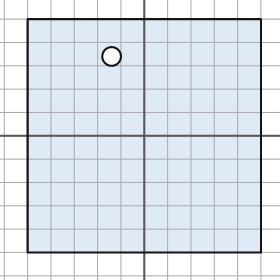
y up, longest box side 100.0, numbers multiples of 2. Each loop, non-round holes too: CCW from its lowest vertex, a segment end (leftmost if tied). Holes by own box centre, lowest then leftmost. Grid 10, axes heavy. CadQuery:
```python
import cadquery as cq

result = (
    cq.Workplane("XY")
    .moveTo(-50.0, -50.0)
    .lineTo(50.0, -50.0)
    .lineTo(50.0, 50.0)
    .lineTo(-50.0, 50.0)
    .close()
    .moveTo(-14.0, 34.0)
    .circle(4.0)
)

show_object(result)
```